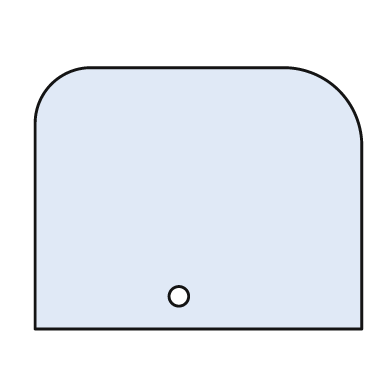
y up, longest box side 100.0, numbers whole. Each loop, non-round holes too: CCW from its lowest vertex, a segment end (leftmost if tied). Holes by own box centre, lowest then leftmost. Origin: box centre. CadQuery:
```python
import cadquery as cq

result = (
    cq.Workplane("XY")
    .moveTo(-50.0, -40.0)
    .lineTo(50.0, -40.0)
    .lineTo(50.0, 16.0)
    .threePointArc((43.0, 33.0), (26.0, 40.0))
    .lineTo(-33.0, 40.0)
    .threePointArc((-45.0, 35.0), (-50.0, 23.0))
    .close()
    .moveTo(-6.0, -30.0)
    .circle(3.0)
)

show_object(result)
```